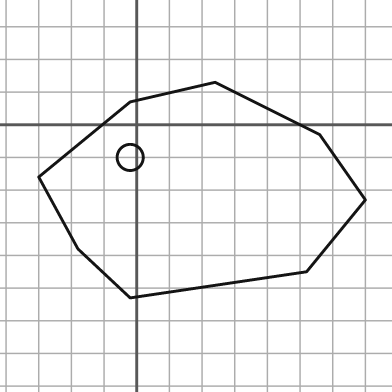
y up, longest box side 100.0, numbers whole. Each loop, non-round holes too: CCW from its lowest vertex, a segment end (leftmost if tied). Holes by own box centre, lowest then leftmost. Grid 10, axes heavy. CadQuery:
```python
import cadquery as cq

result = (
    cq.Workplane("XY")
    .moveTo(-2.0, -53.0)
    .lineTo(52.0, -45.0)
    .lineTo(70.0, -23.0)
    .lineTo(56.0, -3.0)
    .lineTo(24.0, 13.0)
    .lineTo(-2.0, 7.0)
    .lineTo(-30.0, -16.0)
    .lineTo(-18.0, -38.0)
    .close()
    .moveTo(-2.0, -10.0)
    .circle(4.0)
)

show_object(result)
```